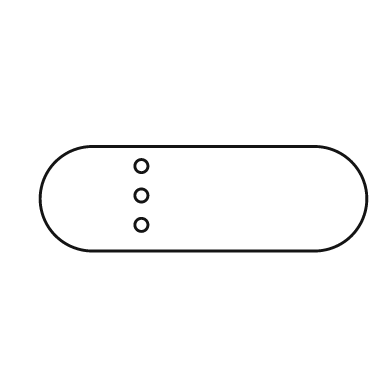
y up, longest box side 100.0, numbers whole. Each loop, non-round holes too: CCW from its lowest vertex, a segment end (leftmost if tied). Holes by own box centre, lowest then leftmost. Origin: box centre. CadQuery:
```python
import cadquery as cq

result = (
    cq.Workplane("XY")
    .moveTo(-34.0, -16.0)
    .lineTo(34.0, -16.0)
    .threePointArc((50.0, 0.0), (34.0, 16.0))
    .lineTo(-34.0, 16.0)
    .threePointArc((-50.0, 0.0), (-34.0, -16.0))
    .close()
    .moveTo(-19.0, -8.0)
    .circle(2.0)
    .moveTo(-19.0, 1.0)
    .circle(2.0)
    .moveTo(-19.0, 10.0)
    .circle(2.0)
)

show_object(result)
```